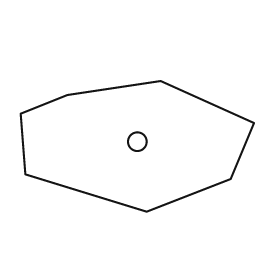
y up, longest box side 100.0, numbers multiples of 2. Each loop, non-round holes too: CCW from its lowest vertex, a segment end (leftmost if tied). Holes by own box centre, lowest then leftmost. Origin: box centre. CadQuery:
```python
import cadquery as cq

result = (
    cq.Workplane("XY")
    .moveTo(4.0, -28.0)
    .lineTo(40.0, -14.0)
    .lineTo(50.0, 10.0)
    .lineTo(10.0, 28.0)
    .lineTo(-30.0, 22.0)
    .lineTo(-50.0, 14.0)
    .lineTo(-48.0, -12.0)
    .close()
    .moveTo(0.0, 2.0)
    .circle(4.0)
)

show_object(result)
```